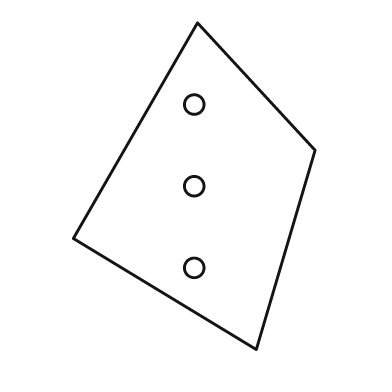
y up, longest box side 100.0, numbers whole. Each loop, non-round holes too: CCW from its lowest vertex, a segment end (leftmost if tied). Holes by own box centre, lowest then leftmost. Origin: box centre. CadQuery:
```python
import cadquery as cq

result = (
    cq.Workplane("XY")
    .moveTo(19.0, -50.0)
    .lineTo(37.0, 11.0)
    .lineTo(1.0, 50.0)
    .lineTo(-37.0, -16.0)
    .close()
    .moveTo(0.0, -25.0)
    .circle(3.0)
    .moveTo(0.0, 0.0)
    .circle(3.0)
    .moveTo(0.0, 25.0)
    .circle(3.0)
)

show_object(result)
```